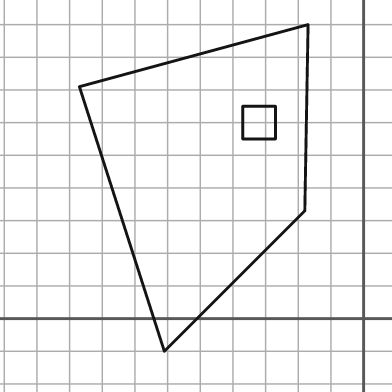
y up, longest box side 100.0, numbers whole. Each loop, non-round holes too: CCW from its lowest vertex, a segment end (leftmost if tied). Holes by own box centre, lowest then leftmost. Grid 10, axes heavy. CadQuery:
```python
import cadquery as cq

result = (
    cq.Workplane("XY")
    .moveTo(-61.0, -10.0)
    .lineTo(-18.0, 33.0)
    .lineTo(-17.0, 90.0)
    .lineTo(-87.0, 71.0)
    .close()
    .moveTo(-37.0, 55.0)
    .lineTo(-27.0, 55.0)
    .lineTo(-27.0, 65.0)
    .lineTo(-37.0, 65.0)
    .close()
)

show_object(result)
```